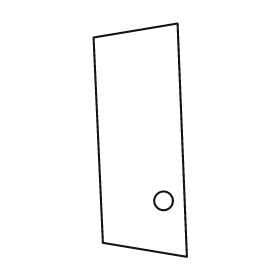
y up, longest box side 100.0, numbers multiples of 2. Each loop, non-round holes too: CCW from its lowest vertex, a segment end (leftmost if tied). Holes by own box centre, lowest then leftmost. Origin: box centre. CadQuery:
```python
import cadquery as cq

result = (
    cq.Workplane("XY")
    .moveTo(20.0, -50.0)
    .lineTo(16.0, 50.0)
    .lineTo(-20.0, 44.0)
    .lineTo(-16.0, -44.0)
    .close()
    .moveTo(10.0, -26.0)
    .circle(4.0)
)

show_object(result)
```